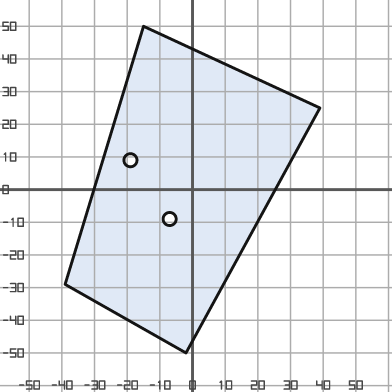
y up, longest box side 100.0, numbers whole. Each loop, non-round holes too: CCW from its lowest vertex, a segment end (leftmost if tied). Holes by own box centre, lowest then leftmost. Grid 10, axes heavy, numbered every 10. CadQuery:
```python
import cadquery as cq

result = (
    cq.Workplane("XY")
    .moveTo(-2.0, -50.0)
    .lineTo(39.0, 25.0)
    .lineTo(-15.0, 50.0)
    .lineTo(-39.0, -29.0)
    .close()
    .moveTo(-7.0, -9.0)
    .circle(2.0)
    .moveTo(-19.0, 9.0)
    .circle(2.0)
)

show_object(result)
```